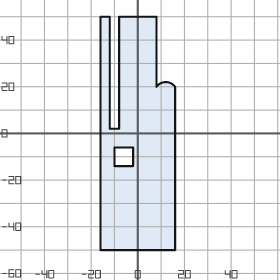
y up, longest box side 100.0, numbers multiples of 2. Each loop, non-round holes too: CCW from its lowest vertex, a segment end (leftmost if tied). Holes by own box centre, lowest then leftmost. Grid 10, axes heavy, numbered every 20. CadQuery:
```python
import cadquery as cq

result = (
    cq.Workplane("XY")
    .moveTo(-16.0, -50.0)
    .lineTo(16.0, -50.0)
    .lineTo(16.0, 20.0)
    .threePointArc((12.0, 22.0), (8.0, 20.0))
    .lineTo(8.0, 50.0)
    .lineTo(-8.0, 50.0)
    .lineTo(-8.0, 2.0)
    .lineTo(-12.0, 2.0)
    .lineTo(-12.0, 50.0)
    .lineTo(-16.0, 50.0)
    .close()
    .moveTo(-10.0, -14.0)
    .lineTo(-2.0, -14.0)
    .lineTo(-2.0, -6.0)
    .lineTo(-10.0, -6.0)
    .close()
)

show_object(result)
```